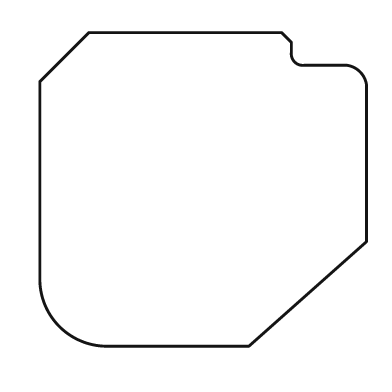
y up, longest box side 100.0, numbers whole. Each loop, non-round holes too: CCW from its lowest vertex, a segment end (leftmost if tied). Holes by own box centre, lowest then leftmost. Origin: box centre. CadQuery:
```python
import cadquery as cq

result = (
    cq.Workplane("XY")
    .moveTo(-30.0, -48.0)
    .lineTo(14.0, -48.0)
    .lineTo(50.0, -16.0)
    .lineTo(50.0, 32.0)
    .threePointArc((48.0, 36.0), (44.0, 38.0))
    .lineTo(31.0, 38.0)
    .threePointArc((28.0, 39.0), (27.0, 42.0))
    .lineTo(27.0, 45.0)
    .lineTo(24.0, 48.0)
    .lineTo(-35.0, 48.0)
    .lineTo(-50.0, 33.0)
    .lineTo(-50.0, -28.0)
    .threePointArc((-44.0, -42.0), (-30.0, -48.0))
    .close()
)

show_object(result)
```